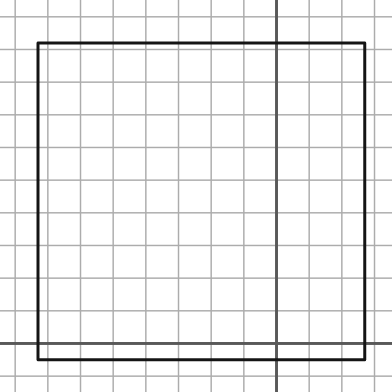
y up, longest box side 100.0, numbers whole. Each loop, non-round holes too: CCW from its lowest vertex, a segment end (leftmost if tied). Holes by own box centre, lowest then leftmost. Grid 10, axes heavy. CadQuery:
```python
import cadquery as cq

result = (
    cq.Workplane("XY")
    .moveTo(-73.0, -5.0)
    .lineTo(27.0, -5.0)
    .lineTo(27.0, 92.0)
    .lineTo(-73.0, 92.0)
    .close()
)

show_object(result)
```